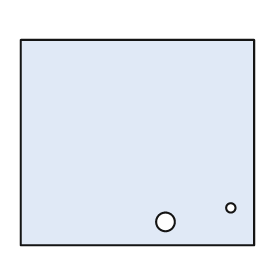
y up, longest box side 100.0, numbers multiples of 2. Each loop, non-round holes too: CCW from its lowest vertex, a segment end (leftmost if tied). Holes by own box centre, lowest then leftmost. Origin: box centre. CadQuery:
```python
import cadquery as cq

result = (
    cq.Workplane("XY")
    .moveTo(-50.0, -44.0)
    .lineTo(50.0, -44.0)
    .lineTo(50.0, 44.0)
    .lineTo(-50.0, 44.0)
    .close()
    .moveTo(12.0, -34.0)
    .circle(4.0)
    .moveTo(40.0, -28.0)
    .circle(2.0)
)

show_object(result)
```